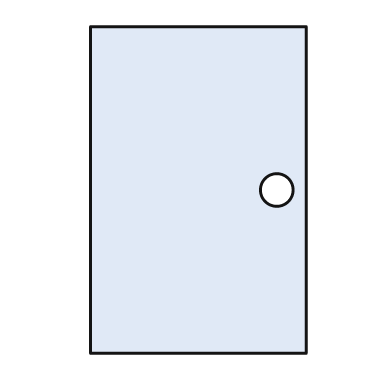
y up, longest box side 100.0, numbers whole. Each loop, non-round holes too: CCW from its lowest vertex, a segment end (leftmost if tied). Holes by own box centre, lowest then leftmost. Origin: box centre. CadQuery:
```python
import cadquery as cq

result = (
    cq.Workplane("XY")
    .moveTo(-33.0, -50.0)
    .lineTo(33.0, -50.0)
    .lineTo(33.0, 50.0)
    .lineTo(-33.0, 50.0)
    .close()
    .moveTo(24.0, 0.0)
    .circle(5.0)
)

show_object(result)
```